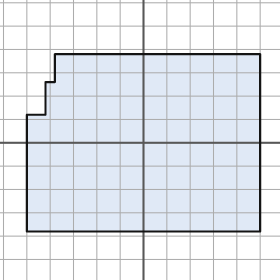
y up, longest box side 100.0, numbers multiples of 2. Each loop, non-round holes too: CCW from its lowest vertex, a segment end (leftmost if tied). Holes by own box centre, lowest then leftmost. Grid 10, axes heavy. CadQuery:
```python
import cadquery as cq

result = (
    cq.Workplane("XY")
    .moveTo(-50.0, -38.0)
    .lineTo(50.0, -38.0)
    .lineTo(50.0, 38.0)
    .lineTo(-38.0, 38.0)
    .lineTo(-38.0, 26.0)
    .lineTo(-42.0, 26.0)
    .lineTo(-42.0, 12.0)
    .lineTo(-50.0, 12.0)
    .close()
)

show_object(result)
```